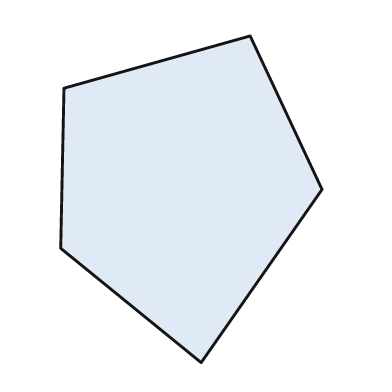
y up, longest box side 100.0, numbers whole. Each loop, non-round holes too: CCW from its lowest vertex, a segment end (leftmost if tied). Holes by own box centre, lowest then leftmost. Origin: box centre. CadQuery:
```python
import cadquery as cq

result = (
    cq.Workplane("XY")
    .moveTo(3.0, -50.0)
    .lineTo(40.0, 3.0)
    .lineTo(18.0, 50.0)
    .lineTo(-39.0, 34.0)
    .lineTo(-40.0, -15.0)
    .close()
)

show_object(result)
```